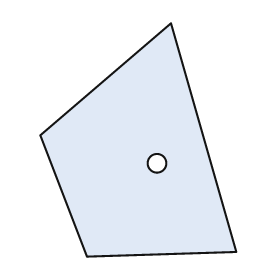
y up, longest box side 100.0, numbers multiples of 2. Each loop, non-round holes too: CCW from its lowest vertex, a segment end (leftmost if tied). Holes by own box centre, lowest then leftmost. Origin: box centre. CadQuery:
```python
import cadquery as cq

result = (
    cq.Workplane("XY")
    .moveTo(-22.0, -50.0)
    .lineTo(42.0, -48.0)
    .lineTo(14.0, 50.0)
    .lineTo(-42.0, 2.0)
    .close()
    .moveTo(8.0, -10.0)
    .circle(4.0)
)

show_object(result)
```